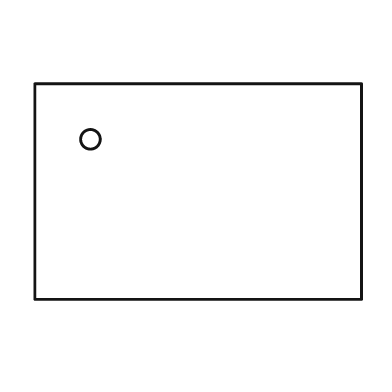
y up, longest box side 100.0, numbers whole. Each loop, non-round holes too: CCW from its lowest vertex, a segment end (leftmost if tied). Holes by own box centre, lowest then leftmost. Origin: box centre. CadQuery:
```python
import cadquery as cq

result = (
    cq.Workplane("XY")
    .moveTo(-50.0, -33.0)
    .lineTo(50.0, -33.0)
    .lineTo(50.0, 33.0)
    .lineTo(-50.0, 33.0)
    .close()
    .moveTo(-33.0, 16.0)
    .circle(3.0)
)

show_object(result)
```